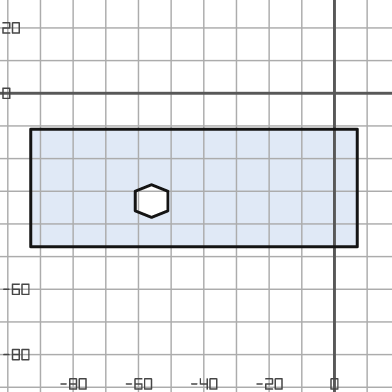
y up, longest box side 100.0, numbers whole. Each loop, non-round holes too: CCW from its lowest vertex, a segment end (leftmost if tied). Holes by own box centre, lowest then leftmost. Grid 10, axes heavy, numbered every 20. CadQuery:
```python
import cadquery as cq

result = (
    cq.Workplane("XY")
    .moveTo(-93.0, -47.0)
    .lineTo(7.0, -47.0)
    .lineTo(7.0, -11.0)
    .lineTo(-93.0, -11.0)
    .close()
    .moveTo(-56.0, -38.0)
    .lineTo(-51.0, -36.0)
    .lineTo(-51.0, -30.0)
    .lineTo(-56.0, -28.0)
    .lineTo(-61.0, -30.0)
    .lineTo(-61.0, -36.0)
    .close()
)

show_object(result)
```